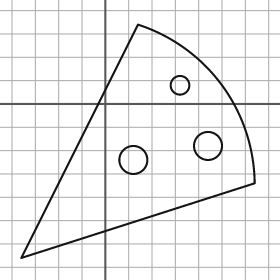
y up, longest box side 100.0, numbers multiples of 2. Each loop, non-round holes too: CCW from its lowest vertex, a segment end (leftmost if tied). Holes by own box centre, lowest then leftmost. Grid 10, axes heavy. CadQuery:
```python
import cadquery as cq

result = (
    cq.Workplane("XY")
    .moveTo(-36.0, -66.0)
    .lineTo(64.0, -34.0)
    .threePointArc((50.0, 8.0), (14.0, 34.0))
    .close()
    .moveTo(12.0, -24.0)
    .circle(6.0)
    .moveTo(44.0, -18.0)
    .circle(6.0)
    .moveTo(32.0, 8.0)
    .circle(4.0)
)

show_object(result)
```